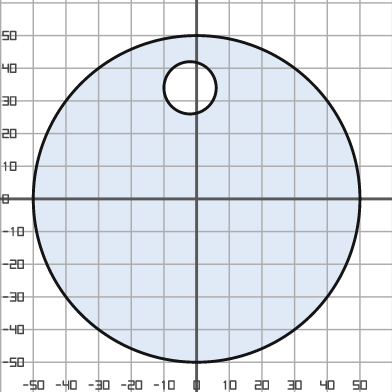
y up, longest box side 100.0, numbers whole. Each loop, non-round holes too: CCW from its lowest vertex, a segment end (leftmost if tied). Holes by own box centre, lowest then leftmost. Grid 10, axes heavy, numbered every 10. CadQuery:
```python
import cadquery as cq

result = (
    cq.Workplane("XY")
    .moveTo(0.0, 0.0)
    .circle(50.0)
    .moveTo(-2.0, 34.0)
    .circle(8.0)
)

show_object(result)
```